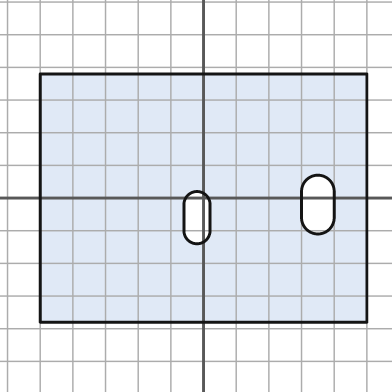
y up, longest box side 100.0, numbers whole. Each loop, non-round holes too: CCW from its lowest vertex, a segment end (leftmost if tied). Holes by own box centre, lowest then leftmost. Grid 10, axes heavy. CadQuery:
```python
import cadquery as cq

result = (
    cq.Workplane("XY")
    .moveTo(-50.0, -38.0)
    .lineTo(50.0, -38.0)
    .lineTo(50.0, 38.0)
    .lineTo(-50.0, 38.0)
    .close()
    .moveTo(-6.0, -10.0)
    .threePointArc((-2.0, -14.0), (2.0, -10.0))
    .lineTo(2.0, -2.0)
    .threePointArc((-2.0, 2.0), (-6.0, -2.0))
    .close()
    .moveTo(30.0, -6.0)
    .threePointArc((35.0, -11.0), (40.0, -6.0))
    .lineTo(40.0, 2.0)
    .threePointArc((35.0, 7.0), (30.0, 2.0))
    .close()
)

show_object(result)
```